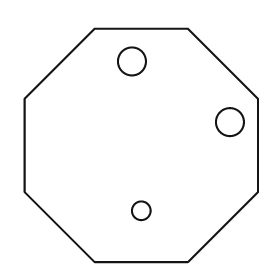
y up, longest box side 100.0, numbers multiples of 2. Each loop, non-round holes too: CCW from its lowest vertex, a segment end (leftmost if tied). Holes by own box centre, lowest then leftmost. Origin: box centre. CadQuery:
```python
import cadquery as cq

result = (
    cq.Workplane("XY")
    .moveTo(-20.0, -50.0)
    .lineTo(20.0, -50.0)
    .lineTo(50.0, -20.0)
    .lineTo(50.0, 20.0)
    .lineTo(20.0, 50.0)
    .lineTo(-20.0, 50.0)
    .lineTo(-50.0, 20.0)
    .lineTo(-50.0, -20.0)
    .close()
    .moveTo(0.0, -28.0)
    .circle(4.0)
    .moveTo(38.0, 10.0)
    .circle(6.0)
    .moveTo(-4.0, 36.0)
    .circle(6.0)
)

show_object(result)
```